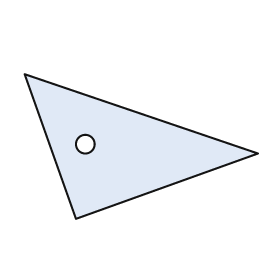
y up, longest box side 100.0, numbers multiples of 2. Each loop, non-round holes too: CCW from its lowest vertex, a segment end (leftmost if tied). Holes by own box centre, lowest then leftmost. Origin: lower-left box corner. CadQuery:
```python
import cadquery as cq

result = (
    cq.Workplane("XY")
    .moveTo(22.0, 0.0)
    .lineTo(100.0, 28.0)
    .lineTo(0.0, 62.0)
    .close()
    .moveTo(26.0, 32.0)
    .circle(4.0)
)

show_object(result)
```